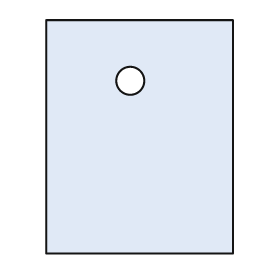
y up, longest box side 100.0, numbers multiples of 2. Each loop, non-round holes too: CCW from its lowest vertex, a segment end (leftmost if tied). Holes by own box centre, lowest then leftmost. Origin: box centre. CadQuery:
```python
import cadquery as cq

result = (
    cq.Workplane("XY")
    .moveTo(-40.0, -50.0)
    .lineTo(40.0, -50.0)
    .lineTo(40.0, 50.0)
    .lineTo(-40.0, 50.0)
    .close()
    .moveTo(-4.0, 24.0)
    .circle(6.0)
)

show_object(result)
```